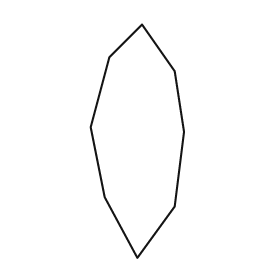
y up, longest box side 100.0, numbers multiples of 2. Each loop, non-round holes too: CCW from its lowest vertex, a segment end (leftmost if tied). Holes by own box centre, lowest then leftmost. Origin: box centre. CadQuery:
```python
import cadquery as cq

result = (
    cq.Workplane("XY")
    .moveTo(0.0, -50.0)
    .lineTo(16.0, -28.0)
    .lineTo(20.0, 4.0)
    .lineTo(16.0, 30.0)
    .lineTo(2.0, 50.0)
    .lineTo(-12.0, 36.0)
    .lineTo(-20.0, 6.0)
    .lineTo(-14.0, -24.0)
    .close()
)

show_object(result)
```